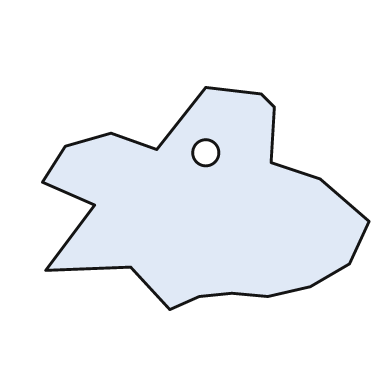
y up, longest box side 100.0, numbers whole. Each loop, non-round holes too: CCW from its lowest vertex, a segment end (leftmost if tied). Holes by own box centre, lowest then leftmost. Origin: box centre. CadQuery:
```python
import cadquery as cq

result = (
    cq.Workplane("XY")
    .moveTo(-11.0, -34.0)
    .lineTo(-2.0, -30.0)
    .lineTo(8.0, -29.0)
    .lineTo(19.0, -30.0)
    .lineTo(32.0, -27.0)
    .lineTo(44.0, -20.0)
    .lineTo(50.0, -7.0)
    .lineTo(35.0, 6.0)
    .lineTo(20.0, 11.0)
    .lineTo(21.0, 28.0)
    .lineTo(17.0, 32.0)
    .lineTo(0.0, 34.0)
    .lineTo(-15.0, 15.0)
    .lineTo(-29.0, 20.0)
    .lineTo(-43.0, 16.0)
    .lineTo(-50.0, 5.0)
    .lineTo(-34.0, -2.0)
    .lineTo(-49.0, -22.0)
    .lineTo(-23.0, -21.0)
    .close()
    .moveTo(0.0, 14.0)
    .circle(4.0)
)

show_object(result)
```